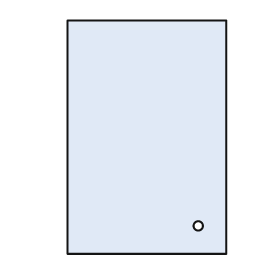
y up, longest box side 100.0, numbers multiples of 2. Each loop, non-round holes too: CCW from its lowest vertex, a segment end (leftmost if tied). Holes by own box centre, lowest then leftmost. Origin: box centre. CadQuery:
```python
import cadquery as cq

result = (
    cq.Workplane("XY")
    .moveTo(-34.0, -50.0)
    .lineTo(34.0, -50.0)
    .lineTo(34.0, 50.0)
    .lineTo(-34.0, 50.0)
    .close()
    .moveTo(22.0, -38.0)
    .circle(2.0)
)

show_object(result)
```